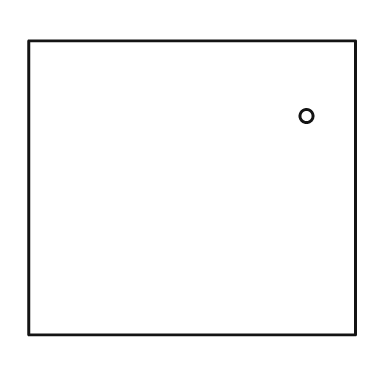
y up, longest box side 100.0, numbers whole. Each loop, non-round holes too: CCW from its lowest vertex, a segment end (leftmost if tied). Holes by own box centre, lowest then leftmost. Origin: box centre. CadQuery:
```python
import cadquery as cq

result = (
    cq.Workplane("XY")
    .moveTo(-50.0, -45.0)
    .lineTo(50.0, -45.0)
    .lineTo(50.0, 45.0)
    .lineTo(-50.0, 45.0)
    .close()
    .moveTo(35.0, 22.0)
    .circle(2.0)
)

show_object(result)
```